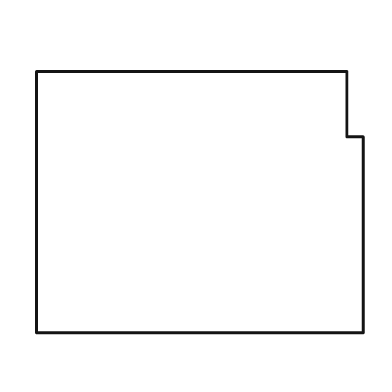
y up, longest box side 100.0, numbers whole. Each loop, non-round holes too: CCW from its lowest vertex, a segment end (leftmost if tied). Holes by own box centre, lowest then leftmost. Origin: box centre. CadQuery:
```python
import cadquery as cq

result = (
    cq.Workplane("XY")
    .moveTo(-50.0, -40.0)
    .lineTo(50.0, -40.0)
    .lineTo(50.0, 20.0)
    .lineTo(45.0, 20.0)
    .lineTo(45.0, 40.0)
    .lineTo(-50.0, 40.0)
    .close()
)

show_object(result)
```